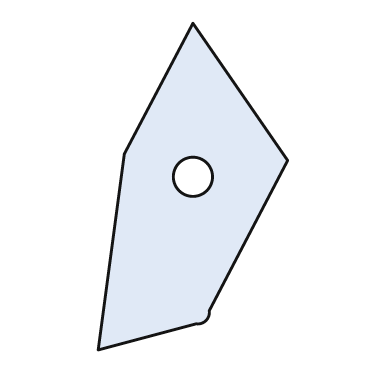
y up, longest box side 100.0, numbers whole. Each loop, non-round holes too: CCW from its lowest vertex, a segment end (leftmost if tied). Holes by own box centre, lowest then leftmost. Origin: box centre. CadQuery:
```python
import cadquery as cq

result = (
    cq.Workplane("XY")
    .moveTo(-29.0, -50.0)
    .lineTo(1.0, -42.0)
    .threePointArc((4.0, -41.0), (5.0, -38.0))
    .lineTo(29.0, 8.0)
    .lineTo(0.0, 50.0)
    .lineTo(-21.0, 10.0)
    .close()
    .moveTo(0.0, 3.0)
    .circle(6.0)
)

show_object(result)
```